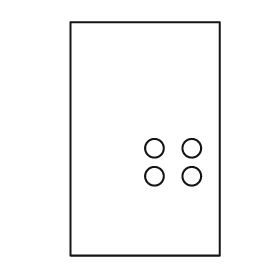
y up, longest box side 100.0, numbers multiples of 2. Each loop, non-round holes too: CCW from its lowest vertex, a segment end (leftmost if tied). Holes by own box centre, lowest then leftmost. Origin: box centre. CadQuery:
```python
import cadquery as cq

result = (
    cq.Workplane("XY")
    .moveTo(-32.0, -50.0)
    .lineTo(32.0, -50.0)
    .lineTo(32.0, 50.0)
    .lineTo(-32.0, 50.0)
    .close()
    .moveTo(4.0, -16.0)
    .circle(4.0)
    .moveTo(20.0, -16.0)
    .circle(4.0)
    .moveTo(4.0, -4.0)
    .circle(4.0)
    .moveTo(20.0, -4.0)
    .circle(4.0)
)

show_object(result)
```